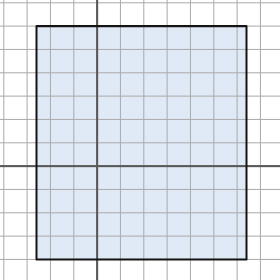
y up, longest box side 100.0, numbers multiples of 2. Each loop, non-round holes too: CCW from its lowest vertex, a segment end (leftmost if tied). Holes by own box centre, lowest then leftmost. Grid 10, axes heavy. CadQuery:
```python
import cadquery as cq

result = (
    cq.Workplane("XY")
    .moveTo(-26.0, -40.0)
    .lineTo(64.0, -40.0)
    .lineTo(64.0, 60.0)
    .lineTo(-26.0, 60.0)
    .close()
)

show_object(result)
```